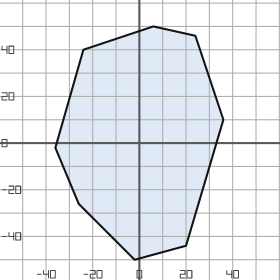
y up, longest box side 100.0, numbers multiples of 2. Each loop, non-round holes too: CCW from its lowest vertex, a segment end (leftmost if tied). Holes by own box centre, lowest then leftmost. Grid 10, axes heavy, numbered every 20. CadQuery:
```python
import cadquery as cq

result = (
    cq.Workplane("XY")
    .moveTo(-2.0, -50.0)
    .lineTo(20.0, -44.0)
    .lineTo(36.0, 10.0)
    .lineTo(24.0, 46.0)
    .lineTo(6.0, 50.0)
    .lineTo(-24.0, 40.0)
    .lineTo(-36.0, -2.0)
    .lineTo(-26.0, -26.0)
    .close()
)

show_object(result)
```